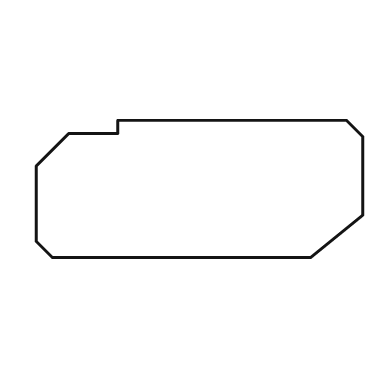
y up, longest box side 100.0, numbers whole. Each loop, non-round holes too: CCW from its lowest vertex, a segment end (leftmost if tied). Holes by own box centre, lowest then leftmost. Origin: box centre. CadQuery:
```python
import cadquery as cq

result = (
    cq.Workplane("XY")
    .moveTo(-45.0, -21.0)
    .lineTo(34.0, -21.0)
    .lineTo(50.0, -8.0)
    .lineTo(50.0, 16.0)
    .lineTo(45.0, 21.0)
    .lineTo(-25.0, 21.0)
    .lineTo(-25.0, 17.0)
    .lineTo(-40.0, 17.0)
    .lineTo(-50.0, 7.0)
    .lineTo(-50.0, -16.0)
    .close()
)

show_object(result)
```